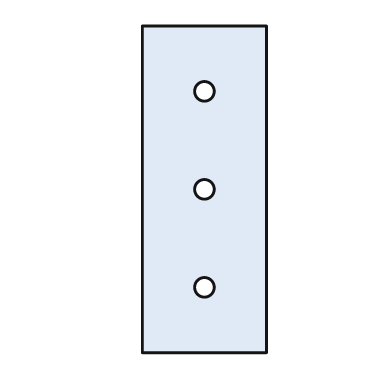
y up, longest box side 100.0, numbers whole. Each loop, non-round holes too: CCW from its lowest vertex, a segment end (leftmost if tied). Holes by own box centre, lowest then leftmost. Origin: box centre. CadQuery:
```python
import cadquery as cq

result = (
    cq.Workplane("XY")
    .moveTo(-19.0, -50.0)
    .lineTo(19.0, -50.0)
    .lineTo(19.0, 50.0)
    .lineTo(-19.0, 50.0)
    .close()
    .moveTo(0.0, -30.0)
    .circle(3.0)
    .moveTo(0.0, 0.0)
    .circle(3.0)
    .moveTo(0.0, 30.0)
    .circle(3.0)
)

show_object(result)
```